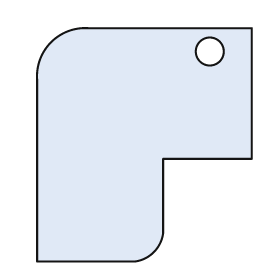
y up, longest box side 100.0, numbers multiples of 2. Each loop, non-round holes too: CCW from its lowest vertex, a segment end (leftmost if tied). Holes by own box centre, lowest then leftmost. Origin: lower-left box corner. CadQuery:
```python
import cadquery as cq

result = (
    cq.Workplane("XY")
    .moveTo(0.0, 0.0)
    .lineTo(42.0, 0.0)
    .threePointArc((50.0, 4.0), (54.0, 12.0))
    .lineTo(54.0, 44.0)
    .lineTo(92.0, 44.0)
    .lineTo(92.0, 100.0)
    .lineTo(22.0, 100.0)
    .threePointArc((6.0, 94.0), (0.0, 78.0))
    .close()
    .moveTo(74.0, 90.0)
    .circle(6.0)
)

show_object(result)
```